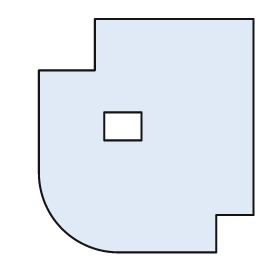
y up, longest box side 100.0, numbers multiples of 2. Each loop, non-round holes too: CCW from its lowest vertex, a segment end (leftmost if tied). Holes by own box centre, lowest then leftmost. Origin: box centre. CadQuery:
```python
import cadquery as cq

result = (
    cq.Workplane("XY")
    .moveTo(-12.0, -50.0)
    .lineTo(30.0, -50.0)
    .lineTo(30.0, -34.0)
    .lineTo(46.0, -34.0)
    .lineTo(46.0, 50.0)
    .lineTo(-22.0, 50.0)
    .lineTo(-22.0, 28.0)
    .lineTo(-46.0, 28.0)
    .lineTo(-46.0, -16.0)
    .threePointArc((-36.0, -40.0), (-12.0, -50.0))
    .close()
    .moveTo(-18.0, -2.0)
    .lineTo(-2.0, -2.0)
    .lineTo(-2.0, 10.0)
    .lineTo(-18.0, 10.0)
    .close()
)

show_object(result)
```